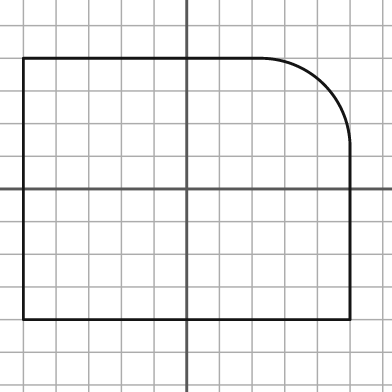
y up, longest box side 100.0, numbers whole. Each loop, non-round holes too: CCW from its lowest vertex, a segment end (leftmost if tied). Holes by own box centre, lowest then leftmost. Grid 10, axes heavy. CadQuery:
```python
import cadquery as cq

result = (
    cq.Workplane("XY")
    .moveTo(-50.0, -40.0)
    .lineTo(50.0, -40.0)
    .lineTo(50.0, 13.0)
    .threePointArc((42.0, 32.0), (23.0, 40.0))
    .lineTo(-50.0, 40.0)
    .close()
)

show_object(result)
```